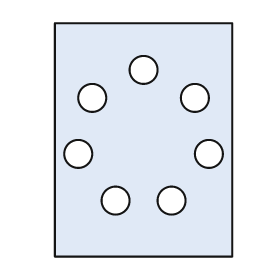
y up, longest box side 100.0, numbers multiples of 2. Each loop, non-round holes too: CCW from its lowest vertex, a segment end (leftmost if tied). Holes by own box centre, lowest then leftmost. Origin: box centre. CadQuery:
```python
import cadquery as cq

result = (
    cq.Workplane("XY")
    .moveTo(-38.0, -50.0)
    .lineTo(38.0, -50.0)
    .lineTo(38.0, 50.0)
    .lineTo(-38.0, 50.0)
    .close()
    .moveTo(-12.0, -26.0)
    .circle(6.0)
    .moveTo(12.0, -26.0)
    .circle(6.0)
    .moveTo(-28.0, -6.0)
    .circle(6.0)
    .moveTo(28.0, -6.0)
    .circle(6.0)
    .moveTo(-22.0, 18.0)
    .circle(6.0)
    .moveTo(22.0, 18.0)
    .circle(6.0)
    .moveTo(0.0, 30.0)
    .circle(6.0)
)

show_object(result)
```